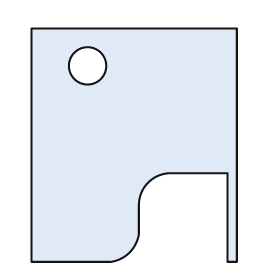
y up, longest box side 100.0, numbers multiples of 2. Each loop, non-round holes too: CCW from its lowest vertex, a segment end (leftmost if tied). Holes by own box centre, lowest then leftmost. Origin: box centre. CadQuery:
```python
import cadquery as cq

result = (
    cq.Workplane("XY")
    .moveTo(-44.0, -50.0)
    .lineTo(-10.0, -50.0)
    .threePointArc((-2.0, -46.0), (2.0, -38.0))
    .lineTo(2.0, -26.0)
    .threePointArc((6.0, -16.0), (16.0, -12.0))
    .lineTo(40.0, -12.0)
    .lineTo(40.0, -50.0)
    .lineTo(44.0, -50.0)
    .lineTo(44.0, 50.0)
    .lineTo(-44.0, 50.0)
    .close()
    .moveTo(-20.0, 34.0)
    .circle(8.0)
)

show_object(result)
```